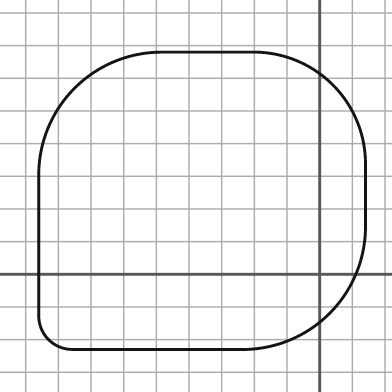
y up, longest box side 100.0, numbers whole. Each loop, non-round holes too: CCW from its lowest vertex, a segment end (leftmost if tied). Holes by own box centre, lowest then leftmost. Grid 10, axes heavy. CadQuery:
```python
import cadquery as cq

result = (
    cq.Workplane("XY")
    .moveTo(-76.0, -23.0)
    .lineTo(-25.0, -23.0)
    .threePointArc((3.0, -12.0), (14.0, 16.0))
    .lineTo(14.0, 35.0)
    .threePointArc((4.0, 58.0), (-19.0, 68.0))
    .lineTo(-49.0, 68.0)
    .threePointArc((-75.0, 57.0), (-86.0, 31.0))
    .lineTo(-86.0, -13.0)
    .threePointArc((-83.0, -20.0), (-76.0, -23.0))
    .close()
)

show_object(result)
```